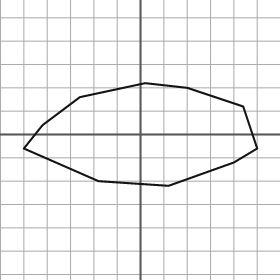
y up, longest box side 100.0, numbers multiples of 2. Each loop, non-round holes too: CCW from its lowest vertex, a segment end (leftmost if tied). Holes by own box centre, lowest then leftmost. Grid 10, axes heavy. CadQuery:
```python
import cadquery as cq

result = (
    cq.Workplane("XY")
    .moveTo(12.0, -22.0)
    .lineTo(40.0, -12.0)
    .lineTo(50.0, -6.0)
    .lineTo(44.0, 12.0)
    .lineTo(20.0, 20.0)
    .lineTo(2.0, 22.0)
    .lineTo(-26.0, 16.0)
    .lineTo(-42.0, 4.0)
    .lineTo(-50.0, -6.0)
    .lineTo(-18.0, -20.0)
    .close()
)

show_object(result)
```